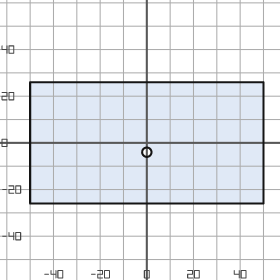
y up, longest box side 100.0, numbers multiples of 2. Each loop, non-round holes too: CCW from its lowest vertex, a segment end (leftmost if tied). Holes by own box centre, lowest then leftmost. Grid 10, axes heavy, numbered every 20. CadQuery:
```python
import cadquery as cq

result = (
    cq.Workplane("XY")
    .moveTo(-50.0, -26.0)
    .lineTo(50.0, -26.0)
    .lineTo(50.0, 26.0)
    .lineTo(-50.0, 26.0)
    .close()
    .moveTo(0.0, -4.0)
    .circle(2.0)
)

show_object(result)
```